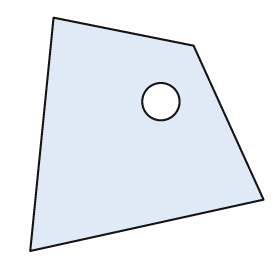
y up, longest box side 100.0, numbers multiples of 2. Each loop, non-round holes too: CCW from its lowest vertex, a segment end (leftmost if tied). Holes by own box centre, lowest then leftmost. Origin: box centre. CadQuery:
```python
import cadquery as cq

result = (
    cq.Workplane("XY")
    .moveTo(-50.0, -50.0)
    .lineTo(50.0, -28.0)
    .lineTo(20.0, 38.0)
    .lineTo(-40.0, 50.0)
    .close()
    .moveTo(6.0, 14.0)
    .circle(8.0)
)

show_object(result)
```